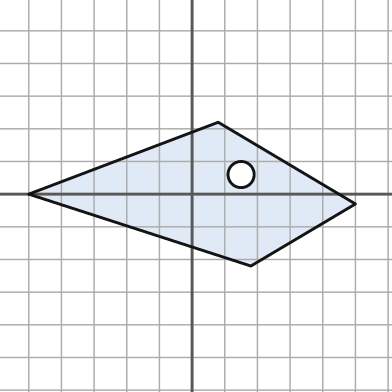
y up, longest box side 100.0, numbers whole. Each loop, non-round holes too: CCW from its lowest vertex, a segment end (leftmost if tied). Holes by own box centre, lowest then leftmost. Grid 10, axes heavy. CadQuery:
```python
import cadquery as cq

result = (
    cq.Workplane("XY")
    .moveTo(18.0, -22.0)
    .lineTo(50.0, -3.0)
    .lineTo(8.0, 22.0)
    .lineTo(-50.0, 0.0)
    .close()
    .moveTo(15.0, 6.0)
    .circle(4.0)
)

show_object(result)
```